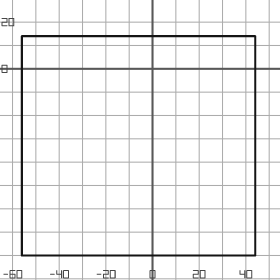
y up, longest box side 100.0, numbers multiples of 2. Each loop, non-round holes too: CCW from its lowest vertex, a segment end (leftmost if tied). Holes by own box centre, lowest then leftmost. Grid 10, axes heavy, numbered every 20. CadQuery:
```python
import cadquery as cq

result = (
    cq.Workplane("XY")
    .moveTo(-56.0, -80.0)
    .lineTo(44.0, -80.0)
    .lineTo(44.0, 14.0)
    .lineTo(-56.0, 14.0)
    .close()
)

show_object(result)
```